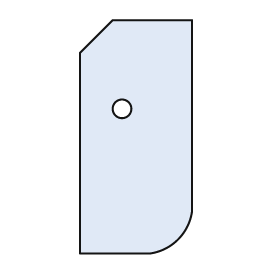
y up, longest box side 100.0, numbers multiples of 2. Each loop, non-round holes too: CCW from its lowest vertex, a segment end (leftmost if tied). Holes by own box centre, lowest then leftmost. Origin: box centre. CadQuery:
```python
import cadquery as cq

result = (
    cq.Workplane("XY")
    .moveTo(-24.0, -50.0)
    .lineTo(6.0, -50.0)
    .threePointArc((18.0, -44.0), (24.0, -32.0))
    .lineTo(24.0, 50.0)
    .lineTo(-10.0, 50.0)
    .lineTo(-24.0, 36.0)
    .close()
    .moveTo(-6.0, 12.0)
    .circle(4.0)
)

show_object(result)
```